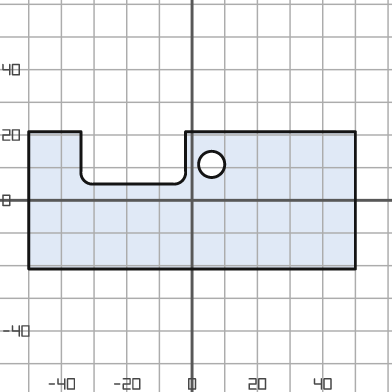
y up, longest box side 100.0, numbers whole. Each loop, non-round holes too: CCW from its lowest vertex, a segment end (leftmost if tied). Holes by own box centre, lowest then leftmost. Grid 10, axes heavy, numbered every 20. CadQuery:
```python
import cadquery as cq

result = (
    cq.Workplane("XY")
    .moveTo(-50.0, -21.0)
    .lineTo(50.0, -21.0)
    .lineTo(50.0, 21.0)
    .lineTo(-2.0, 21.0)
    .lineTo(-2.0, 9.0)
    .threePointArc((-3.0, 6.0), (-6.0, 5.0))
    .lineTo(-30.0, 5.0)
    .threePointArc((-33.0, 6.0), (-34.0, 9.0))
    .lineTo(-34.0, 21.0)
    .lineTo(-50.0, 21.0)
    .close()
    .moveTo(6.0, 11.0)
    .circle(4.0)
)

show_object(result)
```